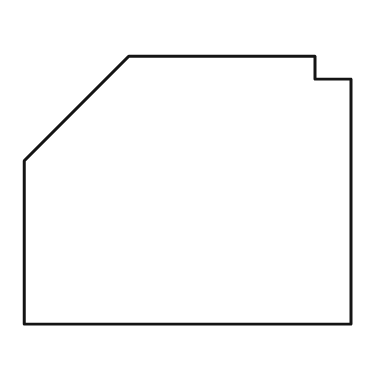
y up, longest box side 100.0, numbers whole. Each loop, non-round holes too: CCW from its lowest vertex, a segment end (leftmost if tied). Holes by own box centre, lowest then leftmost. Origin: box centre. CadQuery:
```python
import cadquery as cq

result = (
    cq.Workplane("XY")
    .moveTo(-50.0, -41.0)
    .lineTo(50.0, -41.0)
    .lineTo(50.0, 34.0)
    .lineTo(39.0, 34.0)
    .lineTo(39.0, 41.0)
    .lineTo(-18.0, 41.0)
    .lineTo(-50.0, 9.0)
    .close()
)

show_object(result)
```